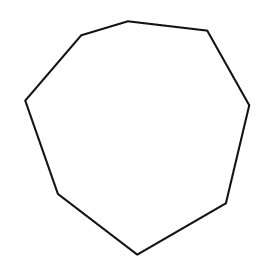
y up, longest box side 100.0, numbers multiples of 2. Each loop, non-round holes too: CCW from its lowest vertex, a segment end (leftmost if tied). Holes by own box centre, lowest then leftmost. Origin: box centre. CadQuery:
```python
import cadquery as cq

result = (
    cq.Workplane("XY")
    .moveTo(0.0, -50.0)
    .lineTo(38.0, -28.0)
    .lineTo(48.0, 14.0)
    .lineTo(30.0, 46.0)
    .lineTo(-4.0, 50.0)
    .lineTo(-24.0, 44.0)
    .lineTo(-48.0, 16.0)
    .lineTo(-34.0, -24.0)
    .close()
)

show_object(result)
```